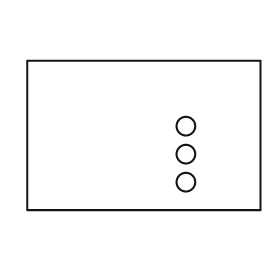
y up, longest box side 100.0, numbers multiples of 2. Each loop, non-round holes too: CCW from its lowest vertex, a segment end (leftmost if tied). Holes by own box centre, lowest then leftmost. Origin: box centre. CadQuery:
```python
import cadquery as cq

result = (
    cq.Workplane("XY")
    .moveTo(-50.0, -32.0)
    .lineTo(50.0, -32.0)
    .lineTo(50.0, 32.0)
    .lineTo(-50.0, 32.0)
    .close()
    .moveTo(18.0, -20.0)
    .circle(4.0)
    .moveTo(18.0, -8.0)
    .circle(4.0)
    .moveTo(18.0, 4.0)
    .circle(4.0)
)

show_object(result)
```